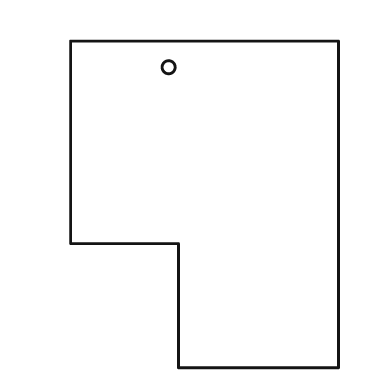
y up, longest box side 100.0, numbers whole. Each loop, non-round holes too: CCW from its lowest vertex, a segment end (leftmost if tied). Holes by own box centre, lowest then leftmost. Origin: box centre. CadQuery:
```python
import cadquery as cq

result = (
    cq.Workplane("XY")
    .moveTo(-8.0, -50.0)
    .lineTo(41.0, -50.0)
    .lineTo(41.0, 50.0)
    .lineTo(-41.0, 50.0)
    .lineTo(-41.0, -12.0)
    .lineTo(-8.0, -12.0)
    .close()
    .moveTo(-11.0, 42.0)
    .circle(2.0)
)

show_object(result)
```